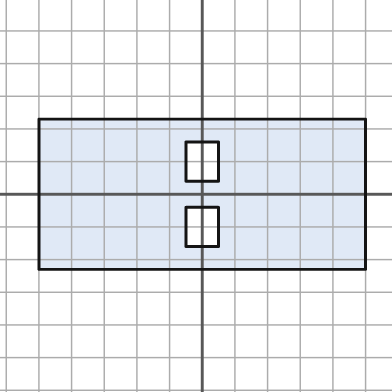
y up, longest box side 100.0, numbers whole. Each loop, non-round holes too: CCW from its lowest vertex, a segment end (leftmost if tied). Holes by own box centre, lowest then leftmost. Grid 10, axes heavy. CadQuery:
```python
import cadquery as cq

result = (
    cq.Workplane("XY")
    .moveTo(-50.0, -23.0)
    .lineTo(50.0, -23.0)
    .lineTo(50.0, 23.0)
    .lineTo(-50.0, 23.0)
    .close()
    .moveTo(-5.0, -16.0)
    .lineTo(5.0, -16.0)
    .lineTo(5.0, -4.0)
    .lineTo(-5.0, -4.0)
    .close()
    .moveTo(-5.0, 4.0)
    .lineTo(5.0, 4.0)
    .lineTo(5.0, 16.0)
    .lineTo(-5.0, 16.0)
    .close()
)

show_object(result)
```